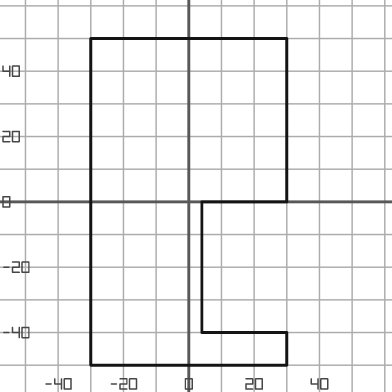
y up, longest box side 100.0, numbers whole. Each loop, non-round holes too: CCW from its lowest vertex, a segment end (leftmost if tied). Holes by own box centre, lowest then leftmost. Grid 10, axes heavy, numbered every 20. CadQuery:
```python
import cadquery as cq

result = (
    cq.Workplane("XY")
    .moveTo(-30.0, -50.0)
    .lineTo(30.0, -50.0)
    .lineTo(30.0, -40.0)
    .lineTo(4.0, -40.0)
    .lineTo(4.0, 0.0)
    .lineTo(30.0, 0.0)
    .lineTo(30.0, 50.0)
    .lineTo(-30.0, 50.0)
    .close()
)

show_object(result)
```